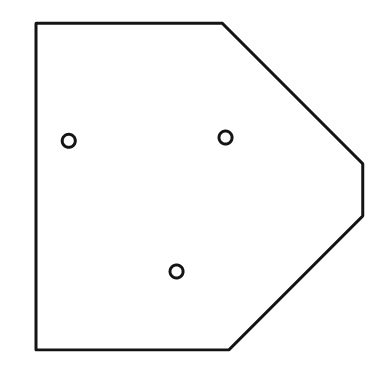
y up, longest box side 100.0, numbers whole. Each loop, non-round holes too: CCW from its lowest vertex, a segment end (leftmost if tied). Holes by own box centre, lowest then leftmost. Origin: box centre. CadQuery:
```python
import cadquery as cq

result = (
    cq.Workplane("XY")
    .moveTo(-50.0, -50.0)
    .lineTo(9.0, -50.0)
    .lineTo(50.0, -9.0)
    .lineTo(50.0, 7.0)
    .lineTo(7.0, 50.0)
    .lineTo(-50.0, 50.0)
    .close()
    .moveTo(-7.0, -26.0)
    .circle(2.0)
    .moveTo(-40.0, 14.0)
    .circle(2.0)
    .moveTo(8.0, 15.0)
    .circle(2.0)
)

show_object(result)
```